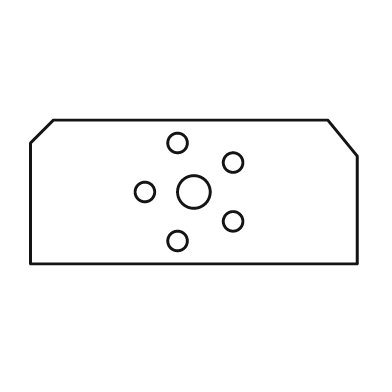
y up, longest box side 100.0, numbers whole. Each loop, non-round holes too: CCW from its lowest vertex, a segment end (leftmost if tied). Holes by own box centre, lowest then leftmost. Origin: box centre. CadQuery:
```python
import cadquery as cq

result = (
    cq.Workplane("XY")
    .moveTo(-50.0, -22.0)
    .lineTo(50.0, -22.0)
    .lineTo(50.0, 11.0)
    .lineTo(41.0, 22.0)
    .lineTo(-43.0, 22.0)
    .lineTo(-50.0, 15.0)
    .close()
    .moveTo(-5.0, -15.0)
    .circle(3.0)
    .moveTo(12.0, -9.0)
    .circle(3.0)
    .moveTo(-15.0, 0.0)
    .circle(3.0)
    .moveTo(0.0, 0.0)
    .circle(5.0)
    .moveTo(12.0, 9.0)
    .circle(3.0)
    .moveTo(-5.0, 15.0)
    .circle(3.0)
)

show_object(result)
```